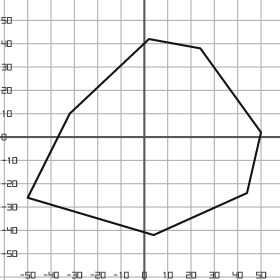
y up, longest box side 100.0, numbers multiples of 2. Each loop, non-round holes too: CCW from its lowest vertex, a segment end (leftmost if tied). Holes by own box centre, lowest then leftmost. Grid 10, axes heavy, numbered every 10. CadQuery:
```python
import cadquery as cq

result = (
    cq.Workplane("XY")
    .moveTo(4.0, -42.0)
    .lineTo(44.0, -24.0)
    .lineTo(50.0, 2.0)
    .lineTo(24.0, 38.0)
    .lineTo(2.0, 42.0)
    .lineTo(-32.0, 10.0)
    .lineTo(-50.0, -26.0)
    .close()
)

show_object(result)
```